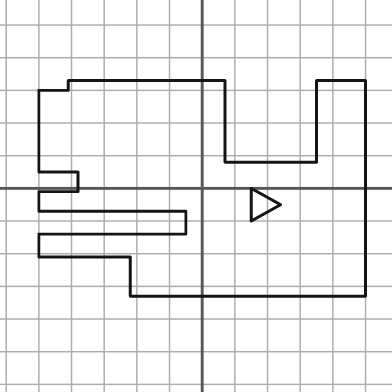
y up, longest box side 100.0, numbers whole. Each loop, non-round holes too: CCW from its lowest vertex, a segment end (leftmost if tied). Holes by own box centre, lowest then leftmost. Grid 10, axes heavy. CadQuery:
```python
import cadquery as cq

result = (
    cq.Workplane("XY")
    .moveTo(-22.0, -33.0)
    .lineTo(50.0, -33.0)
    .lineTo(50.0, 33.0)
    .lineTo(35.0, 33.0)
    .lineTo(35.0, 8.0)
    .lineTo(7.0, 8.0)
    .lineTo(7.0, 33.0)
    .lineTo(-41.0, 33.0)
    .lineTo(-41.0, 30.0)
    .lineTo(-50.0, 30.0)
    .lineTo(-50.0, 5.0)
    .lineTo(-38.0, 5.0)
    .lineTo(-38.0, -1.0)
    .lineTo(-50.0, -1.0)
    .lineTo(-50.0, -7.0)
    .lineTo(-5.0, -7.0)
    .lineTo(-5.0, -14.0)
    .lineTo(-50.0, -14.0)
    .lineTo(-50.0, -21.0)
    .lineTo(-22.0, -21.0)
    .close()
    .moveTo(15.0, -10.0)
    .lineTo(24.0, -5.0)
    .lineTo(15.0, 0.0)
    .close()
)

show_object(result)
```